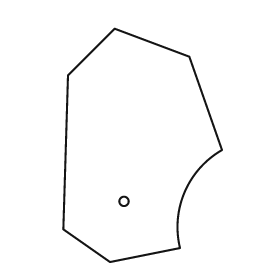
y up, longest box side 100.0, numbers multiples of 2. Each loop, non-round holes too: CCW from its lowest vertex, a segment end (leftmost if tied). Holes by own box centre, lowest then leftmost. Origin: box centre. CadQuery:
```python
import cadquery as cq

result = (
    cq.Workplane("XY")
    .moveTo(-14.0, -50.0)
    .lineTo(16.0, -44.0)
    .threePointArc((18.0, -20.0), (34.0, -2.0))
    .lineTo(20.0, 38.0)
    .lineTo(-12.0, 50.0)
    .lineTo(-32.0, 30.0)
    .lineTo(-34.0, -36.0)
    .close()
    .moveTo(-8.0, -24.0)
    .circle(2.0)
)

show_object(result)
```